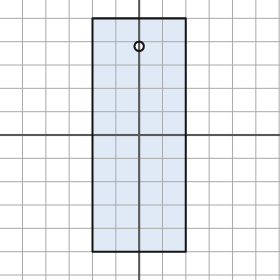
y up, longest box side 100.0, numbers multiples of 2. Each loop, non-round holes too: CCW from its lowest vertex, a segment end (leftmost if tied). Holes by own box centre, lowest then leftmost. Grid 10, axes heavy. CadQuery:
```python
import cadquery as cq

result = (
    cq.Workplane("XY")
    .moveTo(-20.0, -50.0)
    .lineTo(20.0, -50.0)
    .lineTo(20.0, 50.0)
    .lineTo(-20.0, 50.0)
    .close()
    .moveTo(0.0, 38.0)
    .circle(2.0)
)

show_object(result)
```